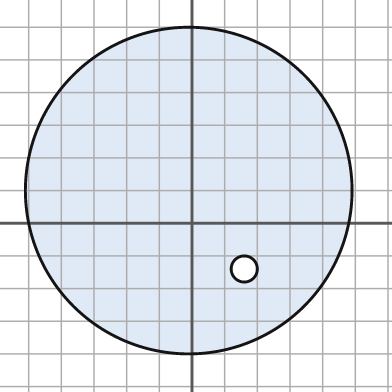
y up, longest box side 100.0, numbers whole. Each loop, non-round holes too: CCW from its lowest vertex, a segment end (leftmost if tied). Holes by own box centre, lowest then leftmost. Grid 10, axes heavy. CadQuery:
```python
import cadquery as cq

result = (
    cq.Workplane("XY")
    .moveTo(-1.0, 10.0)
    .circle(50.0)
    .moveTo(16.0, -14.0)
    .circle(4.0)
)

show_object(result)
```